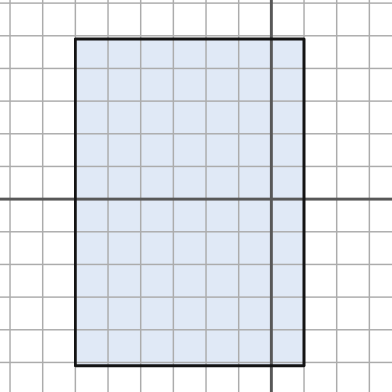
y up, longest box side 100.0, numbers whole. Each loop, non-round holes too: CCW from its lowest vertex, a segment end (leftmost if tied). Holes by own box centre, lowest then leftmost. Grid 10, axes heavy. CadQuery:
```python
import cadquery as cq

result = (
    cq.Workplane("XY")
    .moveTo(-60.0, -51.0)
    .lineTo(10.0, -51.0)
    .lineTo(10.0, 49.0)
    .lineTo(-60.0, 49.0)
    .close()
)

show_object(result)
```